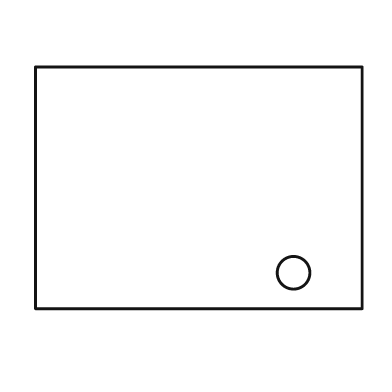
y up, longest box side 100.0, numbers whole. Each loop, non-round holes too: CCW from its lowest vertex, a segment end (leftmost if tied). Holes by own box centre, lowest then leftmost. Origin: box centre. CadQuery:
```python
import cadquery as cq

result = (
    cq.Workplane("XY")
    .moveTo(-50.0, -37.0)
    .lineTo(50.0, -37.0)
    .lineTo(50.0, 37.0)
    .lineTo(-50.0, 37.0)
    .close()
    .moveTo(29.0, -26.0)
    .circle(5.0)
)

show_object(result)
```